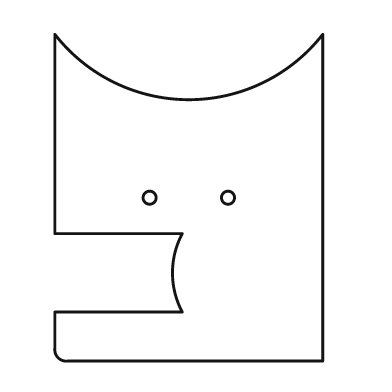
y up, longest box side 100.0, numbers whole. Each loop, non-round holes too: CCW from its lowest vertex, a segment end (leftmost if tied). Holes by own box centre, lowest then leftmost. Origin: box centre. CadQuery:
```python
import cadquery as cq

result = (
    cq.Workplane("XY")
    .moveTo(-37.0, -50.0)
    .lineTo(41.0, -50.0)
    .lineTo(41.0, 50.0)
    .threePointArc((0.0, 30.0), (-41.0, 50.0))
    .lineTo(-41.0, -11.0)
    .lineTo(-2.0, -11.0)
    .threePointArc((-5.0, -23.0), (-2.0, -35.0))
    .lineTo(-41.0, -35.0)
    .lineTo(-41.0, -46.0)
    .threePointArc((-40.0, -49.0), (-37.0, -50.0))
    .close()
    .moveTo(-12.0, 0.0)
    .circle(2.0)
    .moveTo(12.0, 0.0)
    .circle(2.0)
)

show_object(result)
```